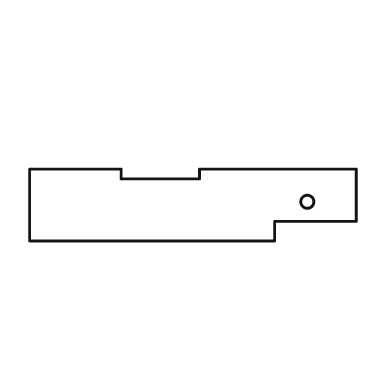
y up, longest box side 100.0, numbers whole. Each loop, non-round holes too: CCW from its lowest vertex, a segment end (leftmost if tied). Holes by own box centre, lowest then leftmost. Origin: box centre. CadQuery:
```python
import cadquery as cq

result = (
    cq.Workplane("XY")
    .moveTo(-50.0, -11.0)
    .lineTo(25.0, -11.0)
    .lineTo(25.0, -5.0)
    .lineTo(50.0, -5.0)
    .lineTo(50.0, 11.0)
    .lineTo(2.0, 11.0)
    .lineTo(2.0, 8.0)
    .lineTo(-22.0, 8.0)
    .lineTo(-22.0, 11.0)
    .lineTo(-50.0, 11.0)
    .close()
    .moveTo(35.0, 1.0)
    .circle(2.0)
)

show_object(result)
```